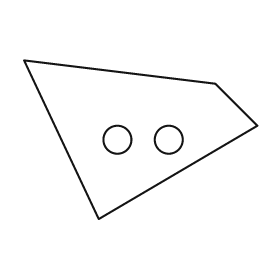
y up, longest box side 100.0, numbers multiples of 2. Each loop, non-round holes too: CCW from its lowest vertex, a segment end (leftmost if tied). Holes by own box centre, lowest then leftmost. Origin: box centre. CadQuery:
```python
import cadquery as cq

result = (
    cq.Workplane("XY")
    .moveTo(-18.0, -34.0)
    .lineTo(50.0, 6.0)
    .lineTo(32.0, 24.0)
    .lineTo(-50.0, 34.0)
    .close()
    .moveTo(-10.0, 0.0)
    .circle(6.0)
    .moveTo(12.0, 0.0)
    .circle(6.0)
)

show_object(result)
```